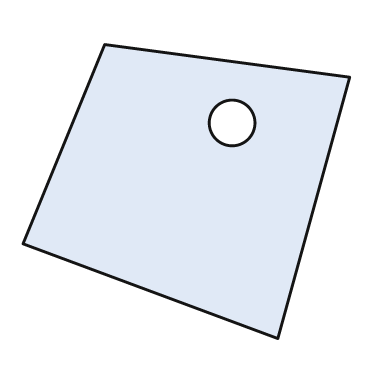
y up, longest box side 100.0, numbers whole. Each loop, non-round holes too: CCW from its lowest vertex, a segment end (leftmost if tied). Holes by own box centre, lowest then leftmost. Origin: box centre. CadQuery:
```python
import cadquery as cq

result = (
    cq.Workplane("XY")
    .moveTo(28.0, -45.0)
    .lineTo(50.0, 35.0)
    .lineTo(-25.0, 45.0)
    .lineTo(-50.0, -16.0)
    .close()
    .moveTo(14.0, 21.0)
    .circle(7.0)
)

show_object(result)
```